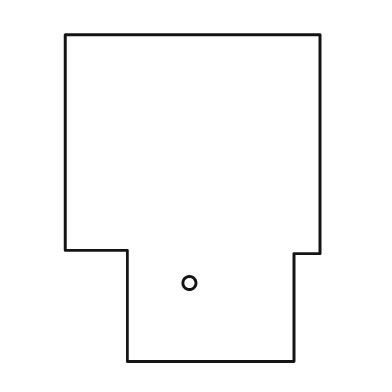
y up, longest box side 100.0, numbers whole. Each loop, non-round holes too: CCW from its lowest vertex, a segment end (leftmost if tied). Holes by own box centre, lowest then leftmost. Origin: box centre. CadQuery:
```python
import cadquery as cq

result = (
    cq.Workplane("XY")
    .moveTo(-20.0, -50.0)
    .lineTo(31.0, -50.0)
    .lineTo(31.0, -17.0)
    .lineTo(39.0, -17.0)
    .lineTo(39.0, 50.0)
    .lineTo(-39.0, 50.0)
    .lineTo(-39.0, -16.0)
    .lineTo(-20.0, -16.0)
    .close()
    .moveTo(-1.0, -26.0)
    .circle(2.0)
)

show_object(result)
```